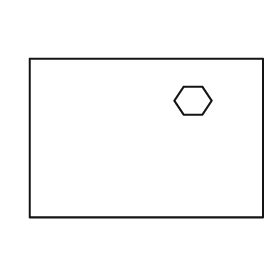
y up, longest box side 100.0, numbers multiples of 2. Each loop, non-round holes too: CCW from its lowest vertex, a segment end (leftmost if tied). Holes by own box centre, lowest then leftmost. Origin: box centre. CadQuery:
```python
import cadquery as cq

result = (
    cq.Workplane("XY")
    .moveTo(-50.0, -34.0)
    .lineTo(50.0, -34.0)
    .lineTo(50.0, 34.0)
    .lineTo(-50.0, 34.0)
    .close()
    .moveTo(16.0, 10.0)
    .lineTo(24.0, 10.0)
    .lineTo(28.0, 16.0)
    .lineTo(24.0, 22.0)
    .lineTo(16.0, 22.0)
    .lineTo(12.0, 16.0)
    .close()
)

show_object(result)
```